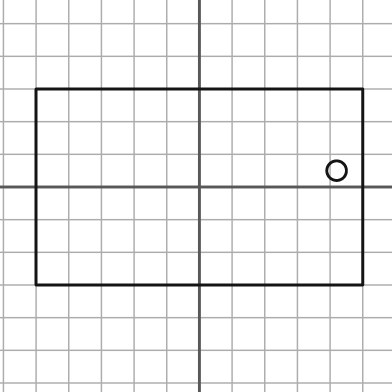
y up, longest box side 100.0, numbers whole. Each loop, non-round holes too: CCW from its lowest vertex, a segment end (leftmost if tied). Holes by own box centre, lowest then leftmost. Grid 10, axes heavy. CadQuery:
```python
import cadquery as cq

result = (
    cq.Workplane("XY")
    .moveTo(-50.0, -30.0)
    .lineTo(50.0, -30.0)
    .lineTo(50.0, 30.0)
    .lineTo(-50.0, 30.0)
    .close()
    .moveTo(42.0, 5.0)
    .circle(3.0)
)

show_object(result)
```